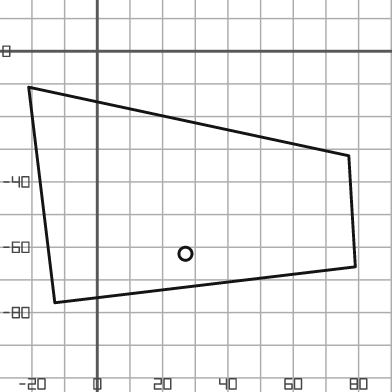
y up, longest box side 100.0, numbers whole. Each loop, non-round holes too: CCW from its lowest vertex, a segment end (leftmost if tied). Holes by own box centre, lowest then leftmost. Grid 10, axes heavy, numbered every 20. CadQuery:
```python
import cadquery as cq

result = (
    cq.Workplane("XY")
    .moveTo(-13.0, -77.0)
    .lineTo(79.0, -66.0)
    .lineTo(77.0, -32.0)
    .lineTo(-21.0, -11.0)
    .close()
    .moveTo(27.0, -62.0)
    .circle(2.0)
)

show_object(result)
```